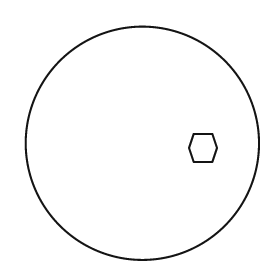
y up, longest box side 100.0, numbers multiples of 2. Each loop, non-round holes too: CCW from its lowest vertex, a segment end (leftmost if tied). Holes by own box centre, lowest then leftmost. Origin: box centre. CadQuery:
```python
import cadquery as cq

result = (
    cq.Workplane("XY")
    .moveTo(0.0, 0.0)
    .circle(50.0)
    .moveTo(22.0, -8.0)
    .lineTo(30.0, -8.0)
    .lineTo(32.0, -2.0)
    .lineTo(30.0, 4.0)
    .lineTo(22.0, 4.0)
    .lineTo(20.0, -2.0)
    .close()
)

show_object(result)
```